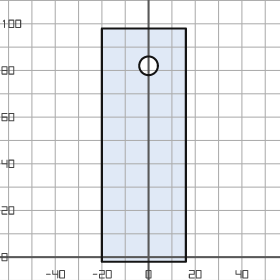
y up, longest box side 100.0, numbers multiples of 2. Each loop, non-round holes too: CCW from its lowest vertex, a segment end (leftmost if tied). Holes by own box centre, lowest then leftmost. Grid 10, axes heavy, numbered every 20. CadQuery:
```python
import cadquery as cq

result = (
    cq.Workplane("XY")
    .moveTo(-20.0, -2.0)
    .lineTo(16.0, -2.0)
    .lineTo(16.0, 98.0)
    .lineTo(-20.0, 98.0)
    .close()
    .moveTo(0.0, 82.0)
    .circle(4.0)
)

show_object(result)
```